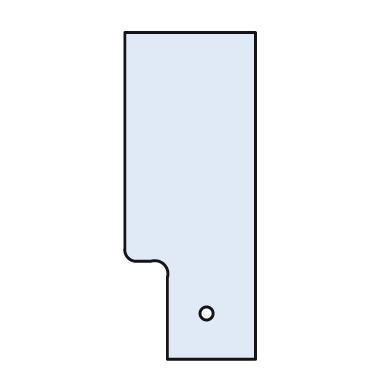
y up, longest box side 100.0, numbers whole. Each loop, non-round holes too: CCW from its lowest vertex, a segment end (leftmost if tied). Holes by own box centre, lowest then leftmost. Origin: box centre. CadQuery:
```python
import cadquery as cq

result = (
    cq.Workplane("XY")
    .moveTo(-7.0, -50.0)
    .lineTo(20.0, -50.0)
    .lineTo(20.0, 50.0)
    .lineTo(-20.0, 50.0)
    .lineTo(-20.0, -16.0)
    .threePointArc((-19.0, -19.0), (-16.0, -20.0))
    .lineTo(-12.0, -20.0)
    .threePointArc((-8.0, -21.0), (-7.0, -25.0))
    .close()
    .moveTo(5.0, -36.0)
    .circle(2.0)
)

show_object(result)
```